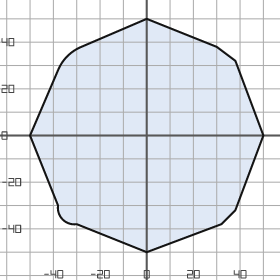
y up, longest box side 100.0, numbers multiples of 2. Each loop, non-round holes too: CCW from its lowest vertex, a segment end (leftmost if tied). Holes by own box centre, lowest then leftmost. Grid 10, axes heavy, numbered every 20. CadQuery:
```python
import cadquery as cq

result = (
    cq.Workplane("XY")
    .moveTo(0.0, -50.0)
    .lineTo(32.0, -38.0)
    .lineTo(38.0, -32.0)
    .lineTo(50.0, 0.0)
    .lineTo(38.0, 32.0)
    .lineTo(30.0, 38.0)
    .lineTo(0.0, 50.0)
    .lineTo(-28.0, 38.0)
    .threePointArc((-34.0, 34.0), (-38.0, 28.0))
    .lineTo(-50.0, 0.0)
    .lineTo(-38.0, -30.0)
    .threePointArc((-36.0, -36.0), (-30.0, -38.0))
    .close()
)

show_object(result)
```